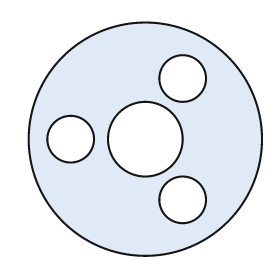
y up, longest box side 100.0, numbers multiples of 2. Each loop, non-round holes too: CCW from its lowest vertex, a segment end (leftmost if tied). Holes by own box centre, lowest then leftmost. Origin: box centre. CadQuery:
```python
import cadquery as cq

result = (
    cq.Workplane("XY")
    .moveTo(0.0, 0.0)
    .circle(50.0)
    .moveTo(16.0, -26.0)
    .circle(10.0)
    .moveTo(-32.0, 0.0)
    .circle(10.0)
    .moveTo(0.0, 0.0)
    .circle(16.0)
    .moveTo(16.0, 26.0)
    .circle(10.0)
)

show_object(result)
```